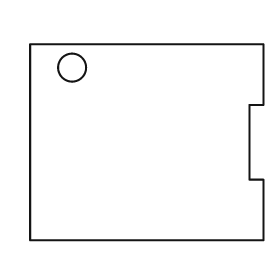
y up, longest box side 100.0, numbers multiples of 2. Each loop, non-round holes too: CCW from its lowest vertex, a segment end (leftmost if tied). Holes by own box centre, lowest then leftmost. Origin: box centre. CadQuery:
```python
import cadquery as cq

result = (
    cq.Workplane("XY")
    .moveTo(-50.0, -42.0)
    .lineTo(50.0, -42.0)
    .lineTo(50.0, -16.0)
    .lineTo(44.0, -16.0)
    .lineTo(44.0, 16.0)
    .lineTo(50.0, 16.0)
    .lineTo(50.0, 42.0)
    .lineTo(-50.0, 42.0)
    .close()
    .moveTo(-32.0, 32.0)
    .circle(6.0)
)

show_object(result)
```